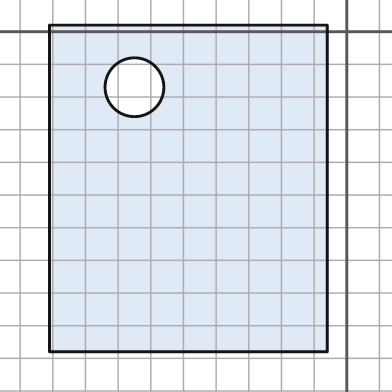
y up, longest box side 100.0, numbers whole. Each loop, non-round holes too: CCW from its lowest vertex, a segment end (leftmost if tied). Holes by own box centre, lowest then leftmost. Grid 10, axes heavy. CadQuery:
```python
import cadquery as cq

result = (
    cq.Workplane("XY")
    .moveTo(-91.0, -98.0)
    .lineTo(-6.0, -98.0)
    .lineTo(-6.0, 2.0)
    .lineTo(-91.0, 2.0)
    .close()
    .moveTo(-65.0, -17.0)
    .circle(9.0)
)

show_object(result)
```